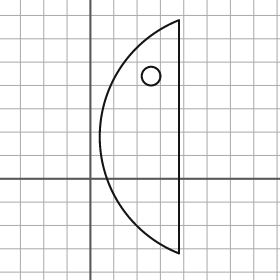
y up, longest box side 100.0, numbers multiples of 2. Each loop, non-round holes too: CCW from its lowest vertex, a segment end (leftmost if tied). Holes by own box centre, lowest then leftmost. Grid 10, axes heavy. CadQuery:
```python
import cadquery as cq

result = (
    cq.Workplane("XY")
    .moveTo(38.0, -32.0)
    .lineTo(38.0, 68.0)
    .threePointArc((4.0, 18.0), (38.0, -32.0))
    .close()
    .moveTo(26.0, 44.0)
    .circle(4.0)
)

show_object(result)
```